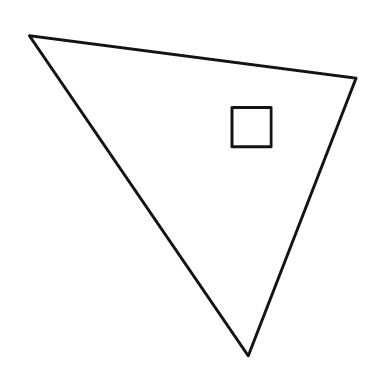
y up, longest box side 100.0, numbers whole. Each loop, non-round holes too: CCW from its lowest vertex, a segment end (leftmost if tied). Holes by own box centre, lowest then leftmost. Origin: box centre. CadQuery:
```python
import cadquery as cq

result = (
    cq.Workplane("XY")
    .moveTo(17.0, -49.0)
    .lineTo(50.0, 36.0)
    .lineTo(-50.0, 49.0)
    .close()
    .moveTo(12.0, 15.0)
    .lineTo(24.0, 15.0)
    .lineTo(24.0, 27.0)
    .lineTo(12.0, 27.0)
    .close()
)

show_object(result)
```